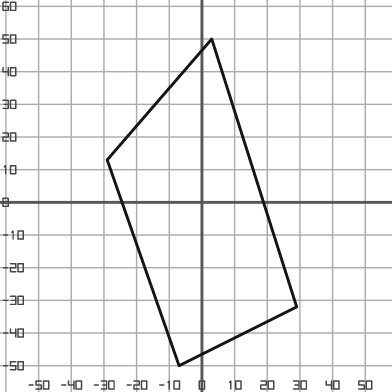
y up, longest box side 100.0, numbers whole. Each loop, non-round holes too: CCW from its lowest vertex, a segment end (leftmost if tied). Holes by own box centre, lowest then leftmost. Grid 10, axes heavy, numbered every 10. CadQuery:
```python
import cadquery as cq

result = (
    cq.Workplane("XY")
    .moveTo(-7.0, -50.0)
    .lineTo(29.0, -32.0)
    .lineTo(3.0, 50.0)
    .lineTo(-29.0, 13.0)
    .close()
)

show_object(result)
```